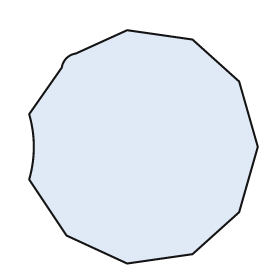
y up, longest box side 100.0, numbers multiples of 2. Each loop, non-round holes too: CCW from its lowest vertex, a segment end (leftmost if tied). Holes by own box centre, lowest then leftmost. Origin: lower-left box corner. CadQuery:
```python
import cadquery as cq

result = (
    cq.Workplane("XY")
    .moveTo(42.0, 0.0)
    .lineTo(70.0, 4.0)
    .lineTo(90.0, 22.0)
    .lineTo(98.0, 50.0)
    .lineTo(90.0, 78.0)
    .lineTo(70.0, 96.0)
    .lineTo(42.0, 100.0)
    .lineTo(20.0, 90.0)
    .threePointArc((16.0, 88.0), (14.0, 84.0))
    .lineTo(0.0, 64.0)
    .threePointArc((2.0, 50.0), (0.0, 36.0))
    .lineTo(16.0, 12.0)
    .close()
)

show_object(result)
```